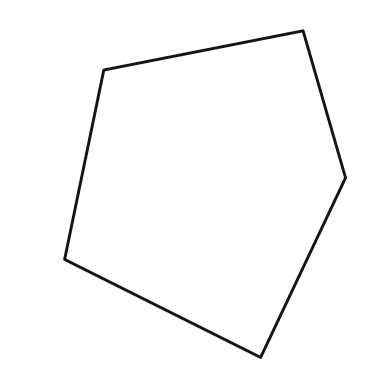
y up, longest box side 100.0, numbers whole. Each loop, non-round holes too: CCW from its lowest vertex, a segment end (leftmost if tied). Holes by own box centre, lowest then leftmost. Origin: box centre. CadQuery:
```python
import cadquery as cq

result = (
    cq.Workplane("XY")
    .moveTo(17.0, -50.0)
    .lineTo(43.0, 5.0)
    .lineTo(30.0, 50.0)
    .lineTo(-31.0, 38.0)
    .lineTo(-43.0, -20.0)
    .close()
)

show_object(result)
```